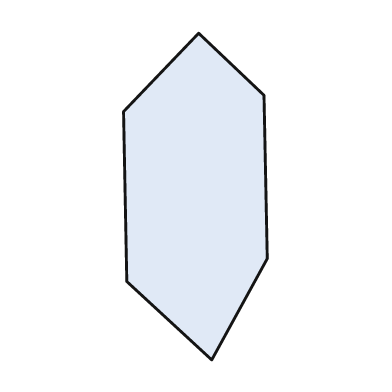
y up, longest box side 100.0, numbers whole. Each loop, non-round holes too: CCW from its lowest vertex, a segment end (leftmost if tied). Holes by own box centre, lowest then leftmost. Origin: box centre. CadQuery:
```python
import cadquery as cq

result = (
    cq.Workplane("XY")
    .moveTo(5.0, -50.0)
    .lineTo(22.0, -19.0)
    .lineTo(21.0, 31.0)
    .lineTo(1.0, 50.0)
    .lineTo(-22.0, 26.0)
    .lineTo(-21.0, -26.0)
    .close()
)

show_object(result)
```